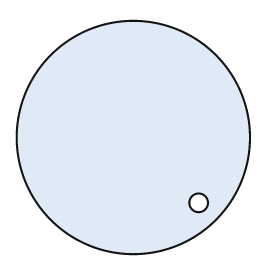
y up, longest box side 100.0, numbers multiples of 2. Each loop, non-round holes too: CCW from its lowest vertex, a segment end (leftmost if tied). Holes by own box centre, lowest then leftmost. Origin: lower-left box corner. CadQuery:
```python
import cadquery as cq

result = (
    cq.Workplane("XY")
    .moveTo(50.0, 50.0)
    .circle(50.0)
    .moveTo(78.0, 22.0)
    .circle(4.0)
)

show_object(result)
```